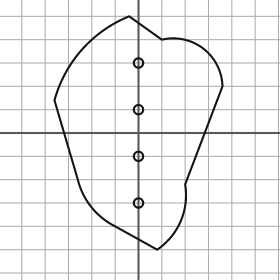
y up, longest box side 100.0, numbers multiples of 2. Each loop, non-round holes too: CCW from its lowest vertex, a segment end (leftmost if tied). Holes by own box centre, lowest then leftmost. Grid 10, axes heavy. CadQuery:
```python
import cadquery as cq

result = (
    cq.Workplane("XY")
    .moveTo(8.0, -50.0)
    .threePointArc((18.0, -38.0), (20.0, -22.0))
    .lineTo(36.0, 20.0)
    .threePointArc((28.0, 36.0), (10.0, 40.0))
    .lineTo(-4.0, 50.0)
    .threePointArc((-24.0, 36.0), (-36.0, 14.0))
    .lineTo(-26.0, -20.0)
    .threePointArc((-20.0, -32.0), (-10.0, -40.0))
    .close()
    .moveTo(0.0, -30.0)
    .circle(2.0)
    .moveTo(0.0, -10.0)
    .circle(2.0)
    .moveTo(0.0, 10.0)
    .circle(2.0)
    .moveTo(0.0, 30.0)
    .circle(2.0)
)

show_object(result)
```